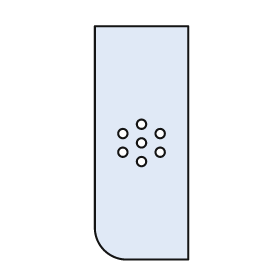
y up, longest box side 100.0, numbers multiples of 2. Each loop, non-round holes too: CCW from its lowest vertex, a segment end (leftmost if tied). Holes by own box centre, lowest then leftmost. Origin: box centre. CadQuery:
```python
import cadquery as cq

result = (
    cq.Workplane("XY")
    .moveTo(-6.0, -50.0)
    .lineTo(20.0, -50.0)
    .lineTo(20.0, 50.0)
    .lineTo(-20.0, 50.0)
    .lineTo(-20.0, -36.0)
    .threePointArc((-16.0, -46.0), (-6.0, -50.0))
    .close()
    .moveTo(0.0, -8.0)
    .circle(2.0)
    .moveTo(-8.0, -4.0)
    .circle(2.0)
    .moveTo(8.0, -4.0)
    .circle(2.0)
    .moveTo(0.0, 0.0)
    .circle(2.0)
    .moveTo(-8.0, 4.0)
    .circle(2.0)
    .moveTo(8.0, 4.0)
    .circle(2.0)
    .moveTo(0.0, 8.0)
    .circle(2.0)
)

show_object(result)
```